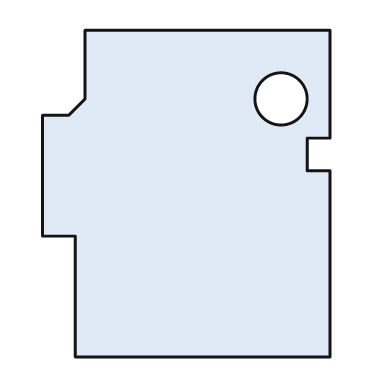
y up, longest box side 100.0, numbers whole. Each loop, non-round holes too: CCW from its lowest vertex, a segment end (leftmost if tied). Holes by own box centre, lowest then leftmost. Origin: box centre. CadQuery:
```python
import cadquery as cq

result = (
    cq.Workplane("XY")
    .moveTo(-34.0, -50.0)
    .lineTo(44.0, -50.0)
    .lineTo(44.0, 7.0)
    .lineTo(37.0, 7.0)
    .lineTo(37.0, 17.0)
    .lineTo(44.0, 17.0)
    .lineTo(44.0, 50.0)
    .lineTo(-31.0, 50.0)
    .lineTo(-31.0, 29.0)
    .lineTo(-36.0, 24.0)
    .lineTo(-44.0, 24.0)
    .lineTo(-44.0, -13.0)
    .lineTo(-34.0, -13.0)
    .close()
    .moveTo(29.0, 29.0)
    .circle(8.0)
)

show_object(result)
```